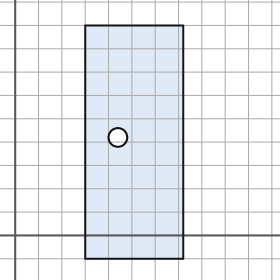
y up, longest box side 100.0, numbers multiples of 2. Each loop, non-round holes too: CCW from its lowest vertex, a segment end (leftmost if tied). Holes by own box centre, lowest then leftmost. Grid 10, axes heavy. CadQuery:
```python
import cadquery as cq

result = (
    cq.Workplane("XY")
    .moveTo(30.0, -10.0)
    .lineTo(72.0, -10.0)
    .lineTo(72.0, 90.0)
    .lineTo(30.0, 90.0)
    .close()
    .moveTo(44.0, 42.0)
    .circle(4.0)
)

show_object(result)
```